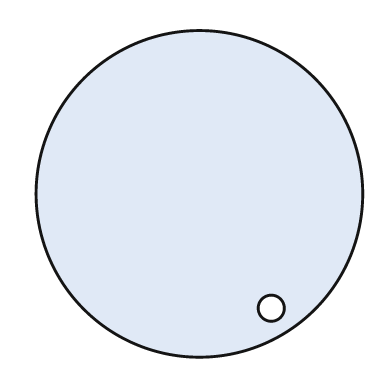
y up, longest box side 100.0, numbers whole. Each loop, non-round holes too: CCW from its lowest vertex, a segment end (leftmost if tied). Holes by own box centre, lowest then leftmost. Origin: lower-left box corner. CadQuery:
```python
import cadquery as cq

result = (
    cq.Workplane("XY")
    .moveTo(50.0, 50.0)
    .circle(50.0)
    .moveTo(72.0, 15.0)
    .circle(4.0)
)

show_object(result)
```